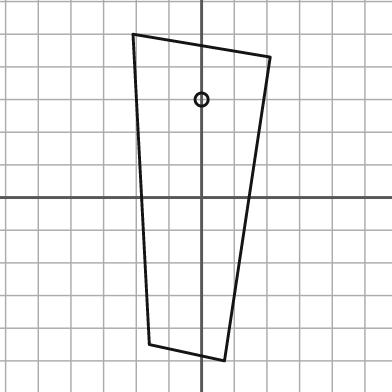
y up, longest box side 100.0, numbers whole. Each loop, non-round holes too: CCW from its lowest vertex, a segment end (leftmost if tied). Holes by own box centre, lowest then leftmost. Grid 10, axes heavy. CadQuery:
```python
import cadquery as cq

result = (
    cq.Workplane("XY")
    .moveTo(7.0, -50.0)
    .lineTo(21.0, 43.0)
    .lineTo(-21.0, 50.0)
    .lineTo(-16.0, -45.0)
    .close()
    .moveTo(0.0, 30.0)
    .circle(2.0)
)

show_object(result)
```